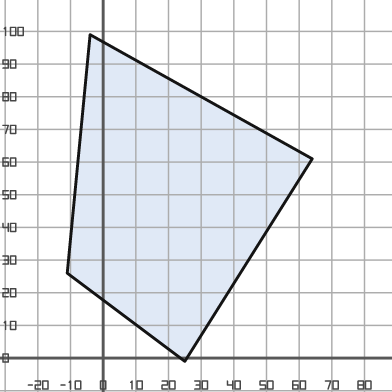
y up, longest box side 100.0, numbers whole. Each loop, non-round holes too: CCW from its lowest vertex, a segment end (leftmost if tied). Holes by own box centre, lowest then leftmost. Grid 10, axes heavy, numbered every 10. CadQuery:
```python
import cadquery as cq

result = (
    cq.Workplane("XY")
    .moveTo(25.0, -1.0)
    .lineTo(64.0, 61.0)
    .lineTo(-4.0, 99.0)
    .lineTo(-11.0, 26.0)
    .close()
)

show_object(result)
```